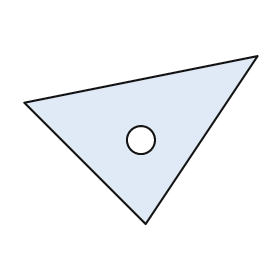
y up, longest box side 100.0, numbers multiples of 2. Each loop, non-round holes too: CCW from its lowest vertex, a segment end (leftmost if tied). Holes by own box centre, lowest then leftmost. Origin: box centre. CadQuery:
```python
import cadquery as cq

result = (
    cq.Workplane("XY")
    .moveTo(2.0, -36.0)
    .lineTo(50.0, 36.0)
    .lineTo(-50.0, 16.0)
    .close()
    .moveTo(0.0, 0.0)
    .circle(6.0)
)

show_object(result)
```